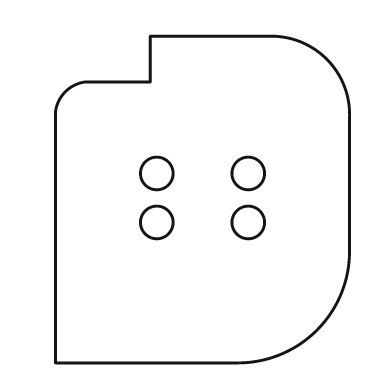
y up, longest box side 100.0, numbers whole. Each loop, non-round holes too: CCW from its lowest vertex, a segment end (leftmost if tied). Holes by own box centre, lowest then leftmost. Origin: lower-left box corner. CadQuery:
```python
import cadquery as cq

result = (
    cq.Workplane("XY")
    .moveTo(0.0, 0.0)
    .lineTo(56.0, 0.0)
    .threePointArc((80.0, 10.0), (90.0, 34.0))
    .lineTo(90.0, 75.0)
    .threePointArc((83.0, 93.0), (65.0, 100.0))
    .lineTo(29.0, 100.0)
    .lineTo(29.0, 86.0)
    .lineTo(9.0, 86.0)
    .threePointArc((3.0, 83.0), (0.0, 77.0))
    .close()
    .moveTo(31.0, 43.0)
    .circle(5.0)
    .moveTo(59.0, 43.0)
    .circle(5.0)
    .moveTo(31.0, 58.0)
    .circle(5.0)
    .moveTo(59.0, 58.0)
    .circle(5.0)
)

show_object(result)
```